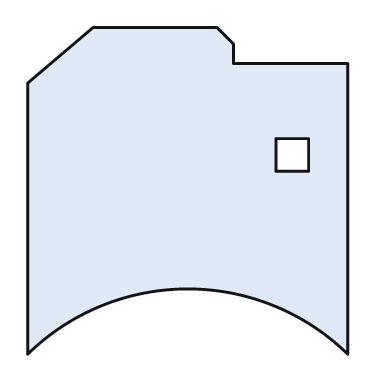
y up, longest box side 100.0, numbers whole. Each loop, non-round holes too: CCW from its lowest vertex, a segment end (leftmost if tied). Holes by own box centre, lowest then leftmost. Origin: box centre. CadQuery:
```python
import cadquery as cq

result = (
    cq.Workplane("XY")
    .moveTo(-49.0, -50.0)
    .threePointArc((0.0, -30.0), (49.0, -50.0))
    .lineTo(49.0, 39.0)
    .lineTo(14.0, 39.0)
    .lineTo(14.0, 45.0)
    .lineTo(9.0, 50.0)
    .lineTo(-29.0, 50.0)
    .lineTo(-49.0, 33.0)
    .close()
    .moveTo(27.0, 6.0)
    .lineTo(37.0, 6.0)
    .lineTo(37.0, 16.0)
    .lineTo(27.0, 16.0)
    .close()
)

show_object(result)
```